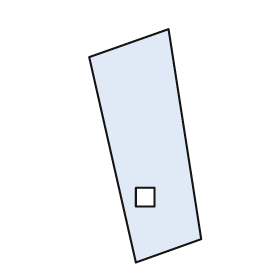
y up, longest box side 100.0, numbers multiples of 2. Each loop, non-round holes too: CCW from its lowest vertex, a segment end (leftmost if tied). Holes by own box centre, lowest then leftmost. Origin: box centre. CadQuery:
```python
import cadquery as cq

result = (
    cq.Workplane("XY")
    .moveTo(-4.0, -50.0)
    .lineTo(24.0, -40.0)
    .lineTo(10.0, 50.0)
    .lineTo(-24.0, 38.0)
    .close()
    .moveTo(-4.0, -26.0)
    .lineTo(4.0, -26.0)
    .lineTo(4.0, -18.0)
    .lineTo(-4.0, -18.0)
    .close()
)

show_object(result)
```